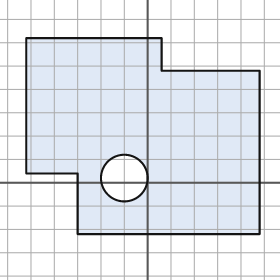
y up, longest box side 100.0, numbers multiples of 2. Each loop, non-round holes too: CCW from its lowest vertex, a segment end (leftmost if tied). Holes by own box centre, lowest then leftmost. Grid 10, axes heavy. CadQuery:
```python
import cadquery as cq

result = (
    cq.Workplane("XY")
    .moveTo(-30.0, -22.0)
    .lineTo(48.0, -22.0)
    .lineTo(48.0, 48.0)
    .lineTo(6.0, 48.0)
    .lineTo(6.0, 62.0)
    .lineTo(-52.0, 62.0)
    .lineTo(-52.0, 4.0)
    .lineTo(-30.0, 4.0)
    .close()
    .moveTo(-10.0, 2.0)
    .circle(10.0)
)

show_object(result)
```